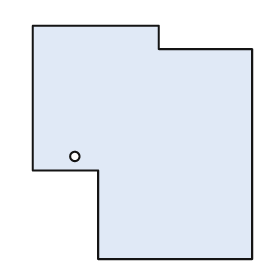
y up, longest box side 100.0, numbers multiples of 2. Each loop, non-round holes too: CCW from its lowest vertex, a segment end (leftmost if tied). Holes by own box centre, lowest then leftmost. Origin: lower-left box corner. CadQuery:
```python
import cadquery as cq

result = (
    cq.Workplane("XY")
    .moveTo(28.0, 0.0)
    .lineTo(94.0, 0.0)
    .lineTo(94.0, 90.0)
    .lineTo(54.0, 90.0)
    .lineTo(54.0, 100.0)
    .lineTo(0.0, 100.0)
    .lineTo(0.0, 38.0)
    .lineTo(28.0, 38.0)
    .close()
    .moveTo(18.0, 44.0)
    .circle(2.0)
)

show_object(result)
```